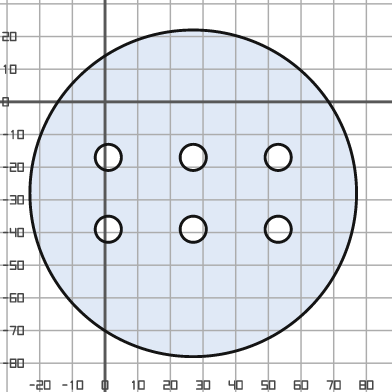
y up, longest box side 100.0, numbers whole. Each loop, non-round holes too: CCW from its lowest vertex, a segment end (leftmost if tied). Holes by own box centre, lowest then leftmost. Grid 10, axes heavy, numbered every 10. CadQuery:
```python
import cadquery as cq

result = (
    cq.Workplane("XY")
    .moveTo(27.0, -28.0)
    .circle(50.0)
    .moveTo(1.0, -39.0)
    .circle(4.0)
    .moveTo(27.0, -39.0)
    .circle(4.0)
    .moveTo(53.0, -39.0)
    .circle(4.0)
    .moveTo(1.0, -17.0)
    .circle(4.0)
    .moveTo(27.0, -17.0)
    .circle(4.0)
    .moveTo(53.0, -17.0)
    .circle(4.0)
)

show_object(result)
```